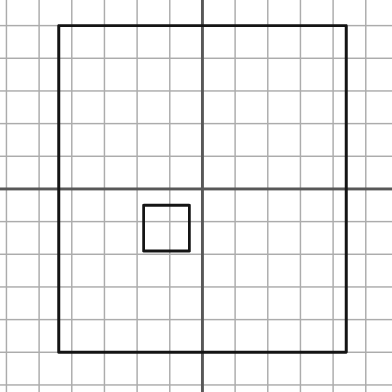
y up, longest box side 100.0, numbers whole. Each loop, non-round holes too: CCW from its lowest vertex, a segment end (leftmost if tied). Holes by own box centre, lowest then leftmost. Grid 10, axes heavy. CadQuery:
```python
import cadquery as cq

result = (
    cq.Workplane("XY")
    .moveTo(-44.0, -50.0)
    .lineTo(44.0, -50.0)
    .lineTo(44.0, 50.0)
    .lineTo(-44.0, 50.0)
    .close()
    .moveTo(-18.0, -19.0)
    .lineTo(-4.0, -19.0)
    .lineTo(-4.0, -5.0)
    .lineTo(-18.0, -5.0)
    .close()
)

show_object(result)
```